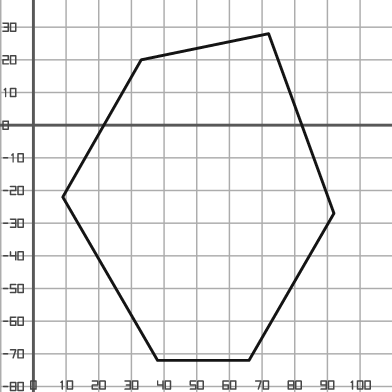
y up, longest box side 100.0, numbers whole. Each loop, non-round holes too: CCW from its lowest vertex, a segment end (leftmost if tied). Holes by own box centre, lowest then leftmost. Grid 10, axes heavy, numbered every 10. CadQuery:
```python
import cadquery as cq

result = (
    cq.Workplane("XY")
    .moveTo(38.0, -72.0)
    .lineTo(66.0, -72.0)
    .lineTo(92.0, -27.0)
    .lineTo(72.0, 28.0)
    .lineTo(33.0, 20.0)
    .lineTo(9.0, -22.0)
    .close()
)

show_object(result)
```